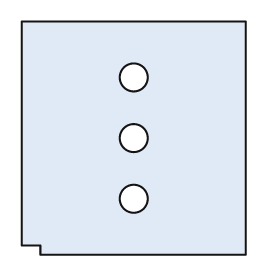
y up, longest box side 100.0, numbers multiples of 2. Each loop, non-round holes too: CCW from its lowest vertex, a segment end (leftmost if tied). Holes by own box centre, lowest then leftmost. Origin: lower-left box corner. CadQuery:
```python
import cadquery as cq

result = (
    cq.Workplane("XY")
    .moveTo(8.0, 0.0)
    .lineTo(96.0, 0.0)
    .lineTo(96.0, 100.0)
    .lineTo(0.0, 100.0)
    .lineTo(0.0, 4.0)
    .lineTo(8.0, 4.0)
    .close()
    .moveTo(48.0, 24.0)
    .circle(6.0)
    .moveTo(48.0, 50.0)
    .circle(6.0)
    .moveTo(48.0, 76.0)
    .circle(6.0)
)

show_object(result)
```